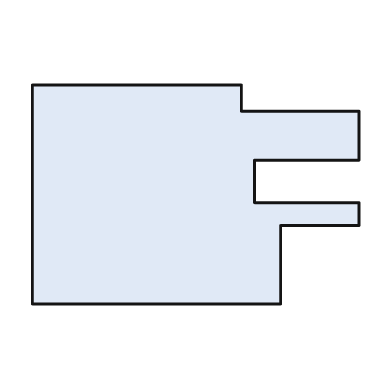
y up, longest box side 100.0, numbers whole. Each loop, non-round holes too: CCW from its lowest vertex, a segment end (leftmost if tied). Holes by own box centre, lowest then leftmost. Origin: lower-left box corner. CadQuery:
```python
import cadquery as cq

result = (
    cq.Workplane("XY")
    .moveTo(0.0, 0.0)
    .lineTo(76.0, 0.0)
    .lineTo(76.0, 24.0)
    .lineTo(100.0, 24.0)
    .lineTo(100.0, 31.0)
    .lineTo(68.0, 31.0)
    .lineTo(68.0, 44.0)
    .lineTo(100.0, 44.0)
    .lineTo(100.0, 59.0)
    .lineTo(64.0, 59.0)
    .lineTo(64.0, 67.0)
    .lineTo(0.0, 67.0)
    .close()
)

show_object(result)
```